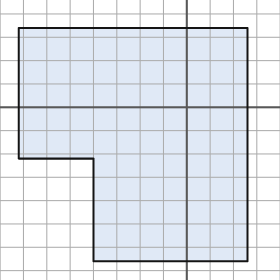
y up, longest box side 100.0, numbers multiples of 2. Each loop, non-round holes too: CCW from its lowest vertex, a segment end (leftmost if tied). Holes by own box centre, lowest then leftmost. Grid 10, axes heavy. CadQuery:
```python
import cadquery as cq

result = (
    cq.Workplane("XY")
    .moveTo(-40.0, -66.0)
    .lineTo(26.0, -66.0)
    .lineTo(26.0, 34.0)
    .lineTo(-72.0, 34.0)
    .lineTo(-72.0, -22.0)
    .lineTo(-40.0, -22.0)
    .close()
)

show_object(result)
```